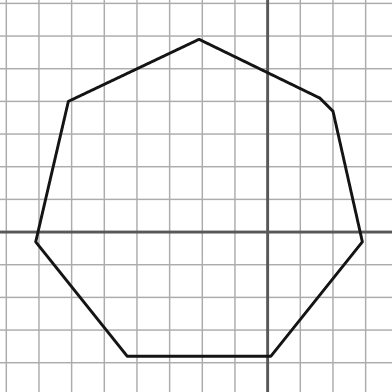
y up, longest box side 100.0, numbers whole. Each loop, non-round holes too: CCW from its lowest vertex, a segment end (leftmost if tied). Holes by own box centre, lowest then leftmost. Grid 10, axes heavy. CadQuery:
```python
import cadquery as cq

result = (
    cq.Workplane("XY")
    .moveTo(-43.0, -38.0)
    .lineTo(1.0, -38.0)
    .lineTo(29.0, -3.0)
    .lineTo(20.0, 37.0)
    .lineTo(16.0, 41.0)
    .lineTo(-21.0, 59.0)
    .lineTo(-61.0, 40.0)
    .lineTo(-71.0, -3.0)
    .close()
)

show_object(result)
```